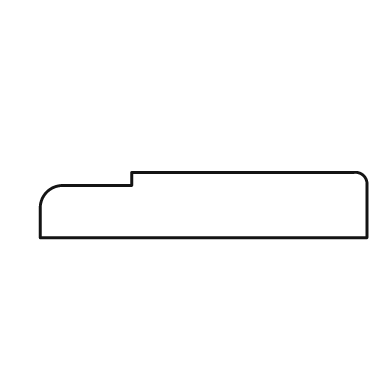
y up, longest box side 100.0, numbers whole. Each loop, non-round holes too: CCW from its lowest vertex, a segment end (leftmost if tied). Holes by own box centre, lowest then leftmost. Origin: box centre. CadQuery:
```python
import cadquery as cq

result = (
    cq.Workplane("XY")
    .moveTo(-50.0, -10.0)
    .lineTo(50.0, -10.0)
    .lineTo(50.0, 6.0)
    .threePointArc((49.0, 9.0), (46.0, 10.0))
    .lineTo(-22.0, 10.0)
    .lineTo(-22.0, 6.0)
    .lineTo(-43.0, 6.0)
    .threePointArc((-48.0, 4.0), (-50.0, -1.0))
    .close()
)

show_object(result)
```